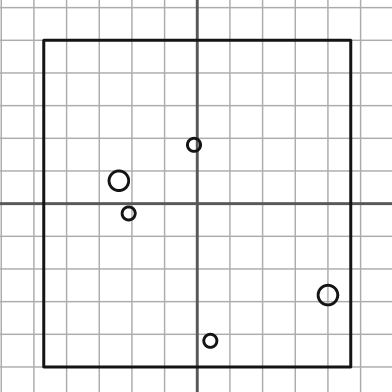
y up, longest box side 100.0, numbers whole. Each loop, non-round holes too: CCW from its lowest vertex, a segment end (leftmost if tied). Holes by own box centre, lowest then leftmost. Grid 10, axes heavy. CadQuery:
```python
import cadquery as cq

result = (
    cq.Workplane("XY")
    .moveTo(-47.0, -50.0)
    .lineTo(47.0, -50.0)
    .lineTo(47.0, 50.0)
    .lineTo(-47.0, 50.0)
    .close()
    .moveTo(4.0, -42.0)
    .circle(2.0)
    .moveTo(40.0, -28.0)
    .circle(3.0)
    .moveTo(-21.0, -3.0)
    .circle(2.0)
    .moveTo(-24.0, 7.0)
    .circle(3.0)
    .moveTo(-1.0, 18.0)
    .circle(2.0)
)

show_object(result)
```